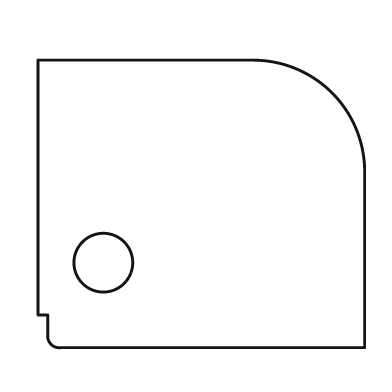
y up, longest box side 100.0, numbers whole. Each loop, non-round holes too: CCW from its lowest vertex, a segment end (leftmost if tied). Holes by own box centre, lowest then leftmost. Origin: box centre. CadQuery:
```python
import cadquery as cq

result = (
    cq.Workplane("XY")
    .moveTo(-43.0, -44.0)
    .lineTo(50.0, -44.0)
    .lineTo(50.0, 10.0)
    .threePointArc((40.0, 34.0), (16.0, 44.0))
    .lineTo(-50.0, 44.0)
    .lineTo(-50.0, -34.0)
    .lineTo(-47.0, -34.0)
    .lineTo(-47.0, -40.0)
    .threePointArc((-46.0, -43.0), (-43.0, -44.0))
    .close()
    .moveTo(-30.0, -18.0)
    .circle(9.0)
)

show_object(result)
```